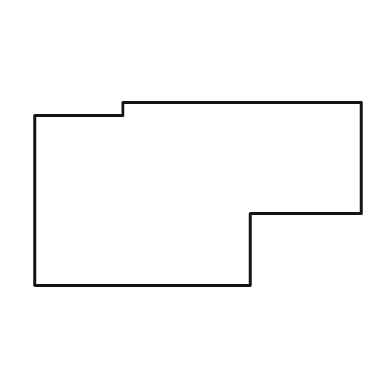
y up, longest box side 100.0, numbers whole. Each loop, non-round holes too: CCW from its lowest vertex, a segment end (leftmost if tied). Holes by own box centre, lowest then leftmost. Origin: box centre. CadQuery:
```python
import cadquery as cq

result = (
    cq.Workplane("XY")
    .moveTo(-50.0, -28.0)
    .lineTo(16.0, -28.0)
    .lineTo(16.0, -6.0)
    .lineTo(50.0, -6.0)
    .lineTo(50.0, 28.0)
    .lineTo(-23.0, 28.0)
    .lineTo(-23.0, 24.0)
    .lineTo(-50.0, 24.0)
    .close()
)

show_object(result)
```